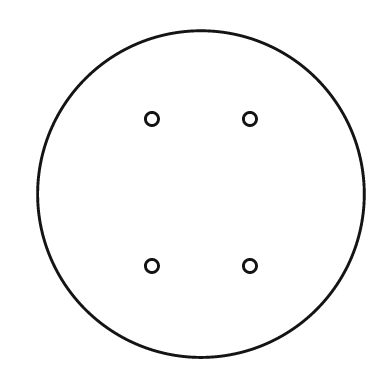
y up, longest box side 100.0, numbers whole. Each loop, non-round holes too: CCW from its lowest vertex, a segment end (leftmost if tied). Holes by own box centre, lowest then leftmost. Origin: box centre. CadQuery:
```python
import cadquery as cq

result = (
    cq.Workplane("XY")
    .moveTo(0.0, 0.0)
    .circle(50.0)
    .moveTo(-15.0, -22.0)
    .circle(2.0)
    .moveTo(15.0, -22.0)
    .circle(2.0)
    .moveTo(-15.0, 23.0)
    .circle(2.0)
    .moveTo(15.0, 23.0)
    .circle(2.0)
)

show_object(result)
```